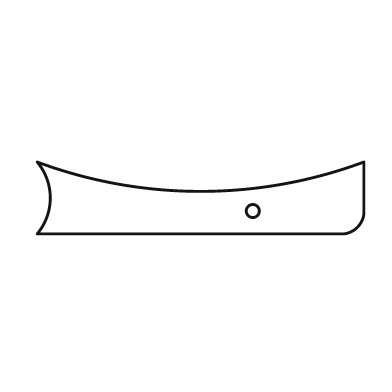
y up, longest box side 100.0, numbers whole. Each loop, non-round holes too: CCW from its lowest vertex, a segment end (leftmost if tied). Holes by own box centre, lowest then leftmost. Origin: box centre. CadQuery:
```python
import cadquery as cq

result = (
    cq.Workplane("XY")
    .moveTo(-50.0, -11.0)
    .lineTo(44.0, -11.0)
    .threePointArc((48.0, -9.0), (50.0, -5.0))
    .lineTo(50.0, 11.0)
    .threePointArc((0.0, 2.0), (-50.0, 11.0))
    .threePointArc((-46.0, 0.0), (-50.0, -11.0))
    .close()
    .moveTo(16.0, -4.0)
    .circle(2.0)
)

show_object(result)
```